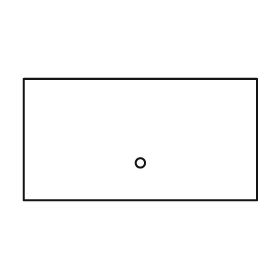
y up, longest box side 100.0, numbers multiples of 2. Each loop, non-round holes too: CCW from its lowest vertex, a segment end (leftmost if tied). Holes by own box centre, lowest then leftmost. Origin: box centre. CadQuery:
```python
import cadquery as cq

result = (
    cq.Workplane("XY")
    .moveTo(-50.0, -26.0)
    .lineTo(50.0, -26.0)
    .lineTo(50.0, 26.0)
    .lineTo(-50.0, 26.0)
    .close()
    .moveTo(0.0, -10.0)
    .circle(2.0)
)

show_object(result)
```